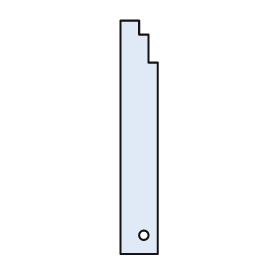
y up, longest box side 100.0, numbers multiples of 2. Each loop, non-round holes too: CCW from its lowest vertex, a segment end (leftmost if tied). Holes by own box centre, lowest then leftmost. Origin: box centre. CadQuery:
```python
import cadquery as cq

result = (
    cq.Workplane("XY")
    .moveTo(-8.0, -50.0)
    .lineTo(8.0, -50.0)
    .lineTo(8.0, 32.0)
    .lineTo(4.0, 32.0)
    .lineTo(4.0, 44.0)
    .lineTo(0.0, 44.0)
    .lineTo(0.0, 50.0)
    .lineTo(-8.0, 50.0)
    .close()
    .moveTo(2.0, -42.0)
    .circle(2.0)
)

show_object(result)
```